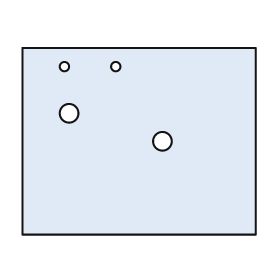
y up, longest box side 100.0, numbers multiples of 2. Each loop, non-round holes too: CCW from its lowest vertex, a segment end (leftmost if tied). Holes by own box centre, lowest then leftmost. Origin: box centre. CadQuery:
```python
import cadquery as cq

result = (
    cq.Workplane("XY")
    .moveTo(-50.0, -40.0)
    .lineTo(50.0, -40.0)
    .lineTo(50.0, 40.0)
    .lineTo(-50.0, 40.0)
    .close()
    .moveTo(10.0, 0.0)
    .circle(4.0)
    .moveTo(-30.0, 12.0)
    .circle(4.0)
    .moveTo(-32.0, 32.0)
    .circle(2.0)
    .moveTo(-10.0, 32.0)
    .circle(2.0)
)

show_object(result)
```